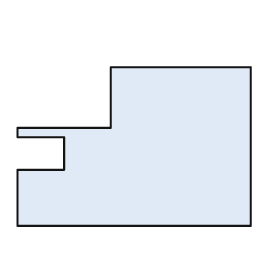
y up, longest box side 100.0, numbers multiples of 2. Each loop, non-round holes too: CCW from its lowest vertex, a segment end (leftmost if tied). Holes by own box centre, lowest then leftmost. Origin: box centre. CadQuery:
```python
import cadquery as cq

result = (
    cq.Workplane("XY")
    .moveTo(-50.0, -34.0)
    .lineTo(50.0, -34.0)
    .lineTo(50.0, 34.0)
    .lineTo(-10.0, 34.0)
    .lineTo(-10.0, 8.0)
    .lineTo(-50.0, 8.0)
    .lineTo(-50.0, 4.0)
    .lineTo(-30.0, 4.0)
    .lineTo(-30.0, -10.0)
    .lineTo(-50.0, -10.0)
    .close()
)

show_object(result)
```